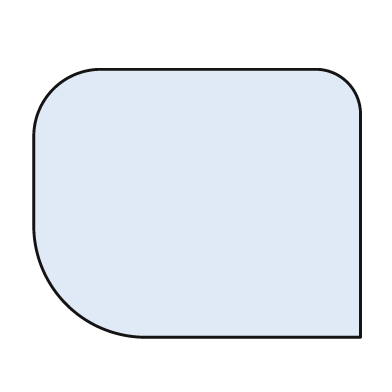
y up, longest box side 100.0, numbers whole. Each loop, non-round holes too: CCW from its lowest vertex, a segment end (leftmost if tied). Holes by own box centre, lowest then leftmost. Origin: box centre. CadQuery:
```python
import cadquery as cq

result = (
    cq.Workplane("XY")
    .moveTo(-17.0, -41.0)
    .lineTo(50.0, -41.0)
    .lineTo(50.0, 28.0)
    .threePointArc((46.0, 37.0), (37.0, 41.0))
    .lineTo(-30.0, 41.0)
    .threePointArc((-44.0, 35.0), (-50.0, 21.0))
    .lineTo(-50.0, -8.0)
    .threePointArc((-40.0, -31.0), (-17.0, -41.0))
    .close()
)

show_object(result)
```